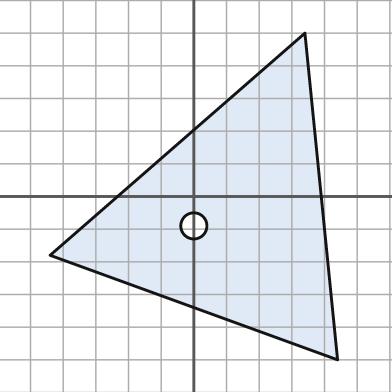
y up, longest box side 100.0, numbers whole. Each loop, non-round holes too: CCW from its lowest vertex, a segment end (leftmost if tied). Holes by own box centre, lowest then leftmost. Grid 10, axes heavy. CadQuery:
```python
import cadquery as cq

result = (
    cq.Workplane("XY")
    .moveTo(44.0, -50.0)
    .lineTo(34.0, 50.0)
    .lineTo(-44.0, -18.0)
    .close()
    .moveTo(0.0, -9.0)
    .circle(4.0)
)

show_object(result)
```